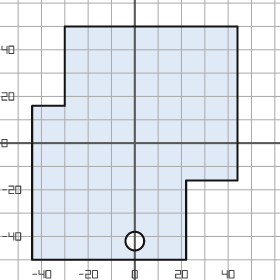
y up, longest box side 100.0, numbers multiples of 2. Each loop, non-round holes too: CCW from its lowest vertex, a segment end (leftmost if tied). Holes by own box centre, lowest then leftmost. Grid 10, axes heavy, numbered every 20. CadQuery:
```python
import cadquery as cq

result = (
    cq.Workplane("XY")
    .moveTo(-44.0, -50.0)
    .lineTo(22.0, -50.0)
    .lineTo(22.0, -16.0)
    .lineTo(44.0, -16.0)
    .lineTo(44.0, 50.0)
    .lineTo(-30.0, 50.0)
    .lineTo(-30.0, 16.0)
    .lineTo(-44.0, 16.0)
    .close()
    .moveTo(0.0, -42.0)
    .circle(4.0)
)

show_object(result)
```